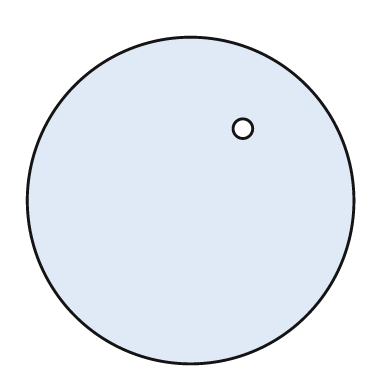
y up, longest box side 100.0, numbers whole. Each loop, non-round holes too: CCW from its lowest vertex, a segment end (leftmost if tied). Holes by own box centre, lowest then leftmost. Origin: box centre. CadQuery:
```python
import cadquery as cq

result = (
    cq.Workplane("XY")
    .moveTo(0.0, 0.0)
    .circle(50.0)
    .moveTo(16.0, 22.0)
    .circle(3.0)
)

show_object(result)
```